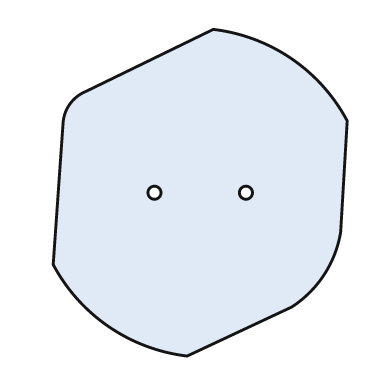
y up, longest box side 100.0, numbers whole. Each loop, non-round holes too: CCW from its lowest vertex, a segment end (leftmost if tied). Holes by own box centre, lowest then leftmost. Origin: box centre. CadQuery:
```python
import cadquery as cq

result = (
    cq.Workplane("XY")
    .moveTo(-4.0, -50.0)
    .lineTo(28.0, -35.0)
    .threePointArc((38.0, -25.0), (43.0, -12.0))
    .lineTo(45.0, 22.0)
    .threePointArc((28.0, 41.0), (4.0, 50.0))
    .lineTo(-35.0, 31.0)
    .threePointArc((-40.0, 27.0), (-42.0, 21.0))
    .lineTo(-45.0, -22.0)
    .threePointArc((-28.0, -41.0), (-4.0, -50.0))
    .close()
    .moveTo(-14.0, 0.0)
    .circle(2.0)
    .moveTo(14.0, 0.0)
    .circle(2.0)
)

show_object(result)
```